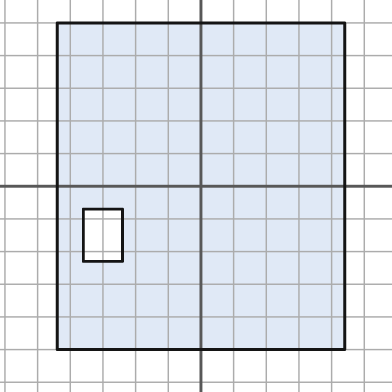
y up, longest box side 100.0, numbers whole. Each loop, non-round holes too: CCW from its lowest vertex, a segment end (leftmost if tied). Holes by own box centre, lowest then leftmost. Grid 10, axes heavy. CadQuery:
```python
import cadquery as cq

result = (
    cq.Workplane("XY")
    .moveTo(-44.0, -50.0)
    .lineTo(44.0, -50.0)
    .lineTo(44.0, 50.0)
    .lineTo(-44.0, 50.0)
    .close()
    .moveTo(-36.0, -23.0)
    .lineTo(-24.0, -23.0)
    .lineTo(-24.0, -7.0)
    .lineTo(-36.0, -7.0)
    .close()
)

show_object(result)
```